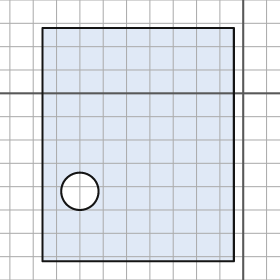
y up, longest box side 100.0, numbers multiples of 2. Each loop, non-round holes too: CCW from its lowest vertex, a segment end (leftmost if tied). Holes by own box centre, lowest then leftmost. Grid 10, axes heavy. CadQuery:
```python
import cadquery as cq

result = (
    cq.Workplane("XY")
    .moveTo(-86.0, -72.0)
    .lineTo(-4.0, -72.0)
    .lineTo(-4.0, 28.0)
    .lineTo(-86.0, 28.0)
    .close()
    .moveTo(-70.0, -42.0)
    .circle(8.0)
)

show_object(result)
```